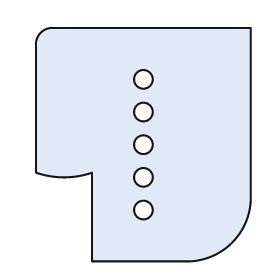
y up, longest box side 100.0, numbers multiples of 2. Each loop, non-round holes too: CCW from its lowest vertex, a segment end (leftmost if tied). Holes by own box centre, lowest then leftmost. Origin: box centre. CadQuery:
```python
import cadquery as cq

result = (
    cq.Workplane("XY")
    .moveTo(-22.0, -50.0)
    .lineTo(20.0, -50.0)
    .threePointArc((38.0, -42.0), (46.0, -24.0))
    .lineTo(46.0, 50.0)
    .lineTo(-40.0, 50.0)
    .threePointArc((-44.0, 48.0), (-46.0, 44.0))
    .lineTo(-46.0, -12.0)
    .threePointArc((-34.0, -14.0), (-22.0, -12.0))
    .close()
    .moveTo(0.0, -28.0)
    .circle(4.0)
    .moveTo(0.0, -14.0)
    .circle(4.0)
    .moveTo(0.0, 0.0)
    .circle(4.0)
    .moveTo(0.0, 14.0)
    .circle(4.0)
    .moveTo(0.0, 28.0)
    .circle(4.0)
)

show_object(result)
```